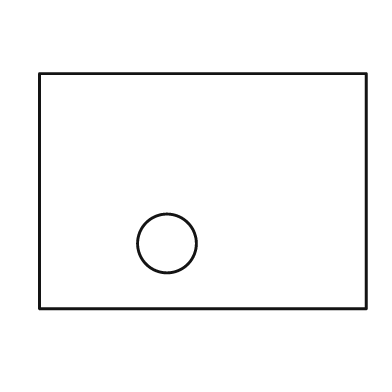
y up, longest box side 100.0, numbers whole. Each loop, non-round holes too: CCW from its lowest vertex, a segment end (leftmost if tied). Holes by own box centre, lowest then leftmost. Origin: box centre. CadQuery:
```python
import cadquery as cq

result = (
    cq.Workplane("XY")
    .moveTo(-50.0, -36.0)
    .lineTo(50.0, -36.0)
    .lineTo(50.0, 36.0)
    .lineTo(-50.0, 36.0)
    .close()
    .moveTo(-11.0, -16.0)
    .circle(9.0)
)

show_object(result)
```